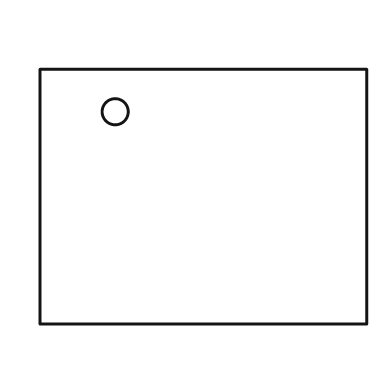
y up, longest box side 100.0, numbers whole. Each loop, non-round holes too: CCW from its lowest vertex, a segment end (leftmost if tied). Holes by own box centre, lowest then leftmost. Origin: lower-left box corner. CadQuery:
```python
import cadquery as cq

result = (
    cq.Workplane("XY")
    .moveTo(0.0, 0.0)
    .lineTo(100.0, 0.0)
    .lineTo(100.0, 78.0)
    .lineTo(0.0, 78.0)
    .close()
    .moveTo(23.0, 65.0)
    .circle(4.0)
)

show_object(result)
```